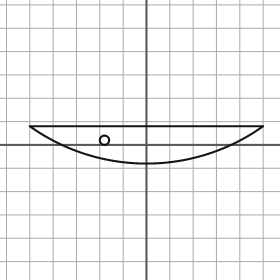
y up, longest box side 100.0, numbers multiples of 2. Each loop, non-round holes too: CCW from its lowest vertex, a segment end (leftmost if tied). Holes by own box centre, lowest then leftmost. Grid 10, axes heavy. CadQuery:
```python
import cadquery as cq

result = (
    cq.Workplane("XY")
    .moveTo(-50.0, 8.0)
    .threePointArc((0.0, -8.0), (50.0, 8.0))
    .close()
    .moveTo(-18.0, 2.0)
    .circle(2.0)
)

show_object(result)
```